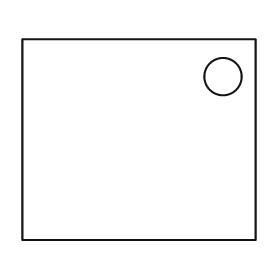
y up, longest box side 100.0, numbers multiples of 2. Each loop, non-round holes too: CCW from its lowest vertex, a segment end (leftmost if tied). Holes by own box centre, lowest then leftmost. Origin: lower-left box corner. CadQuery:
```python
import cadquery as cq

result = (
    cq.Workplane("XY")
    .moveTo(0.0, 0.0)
    .lineTo(100.0, 0.0)
    .lineTo(100.0, 86.0)
    .lineTo(0.0, 86.0)
    .close()
    .moveTo(86.0, 70.0)
    .circle(8.0)
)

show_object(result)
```